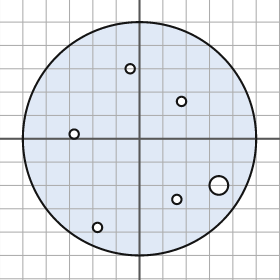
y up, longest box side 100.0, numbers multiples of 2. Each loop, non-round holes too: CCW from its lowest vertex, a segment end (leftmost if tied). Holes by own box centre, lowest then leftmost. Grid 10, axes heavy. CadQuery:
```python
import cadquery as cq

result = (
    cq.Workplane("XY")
    .moveTo(0.0, 0.0)
    .circle(50.0)
    .moveTo(-18.0, -38.0)
    .circle(2.0)
    .moveTo(16.0, -26.0)
    .circle(2.0)
    .moveTo(34.0, -20.0)
    .circle(4.0)
    .moveTo(-28.0, 2.0)
    .circle(2.0)
    .moveTo(18.0, 16.0)
    .circle(2.0)
    .moveTo(-4.0, 30.0)
    .circle(2.0)
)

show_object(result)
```